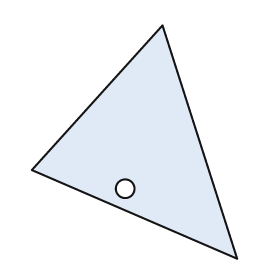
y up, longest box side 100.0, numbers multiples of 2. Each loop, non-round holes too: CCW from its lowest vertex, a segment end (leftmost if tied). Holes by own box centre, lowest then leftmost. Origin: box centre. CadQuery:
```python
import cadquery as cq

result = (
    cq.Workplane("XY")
    .moveTo(44.0, -50.0)
    .lineTo(12.0, 50.0)
    .lineTo(-44.0, -12.0)
    .close()
    .moveTo(-4.0, -20.0)
    .circle(4.0)
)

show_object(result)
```